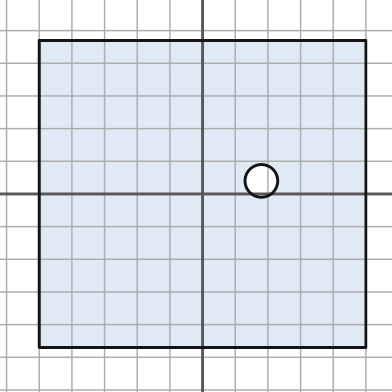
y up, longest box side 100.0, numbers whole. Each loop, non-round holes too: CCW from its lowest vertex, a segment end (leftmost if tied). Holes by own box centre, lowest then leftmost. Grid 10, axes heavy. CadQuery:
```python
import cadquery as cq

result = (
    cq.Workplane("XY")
    .moveTo(-50.0, -47.0)
    .lineTo(50.0, -47.0)
    .lineTo(50.0, 47.0)
    .lineTo(-50.0, 47.0)
    .close()
    .moveTo(18.0, 4.0)
    .circle(5.0)
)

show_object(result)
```